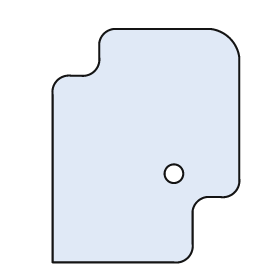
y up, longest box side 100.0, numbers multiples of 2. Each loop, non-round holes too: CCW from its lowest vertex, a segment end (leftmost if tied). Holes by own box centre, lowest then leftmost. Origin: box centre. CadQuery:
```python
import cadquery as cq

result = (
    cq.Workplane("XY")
    .moveTo(-40.0, -50.0)
    .lineTo(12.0, -50.0)
    .threePointArc((18.0, -48.0), (20.0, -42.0))
    .lineTo(20.0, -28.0)
    .threePointArc((22.0, -24.0), (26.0, -22.0))
    .lineTo(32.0, -22.0)
    .threePointArc((38.0, -20.0), (40.0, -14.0))
    .lineTo(40.0, 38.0)
    .threePointArc((36.0, 46.0), (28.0, 50.0))
    .lineTo(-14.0, 50.0)
    .threePointArc((-18.0, 48.0), (-20.0, 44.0))
    .lineTo(-20.0, 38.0)
    .threePointArc((-22.0, 32.0), (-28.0, 30.0))
    .lineTo(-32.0, 30.0)
    .threePointArc((-38.0, 28.0), (-40.0, 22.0))
    .close()
    .moveTo(12.0, -12.0)
    .circle(4.0)
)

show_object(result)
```